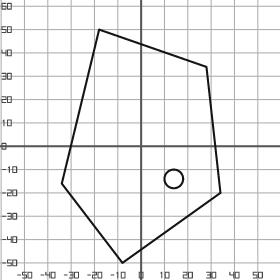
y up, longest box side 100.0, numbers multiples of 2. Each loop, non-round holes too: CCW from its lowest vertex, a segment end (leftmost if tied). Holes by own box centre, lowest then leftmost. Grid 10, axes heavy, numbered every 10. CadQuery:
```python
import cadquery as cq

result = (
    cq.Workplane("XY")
    .moveTo(-8.0, -50.0)
    .lineTo(34.0, -20.0)
    .lineTo(28.0, 34.0)
    .lineTo(-18.0, 50.0)
    .lineTo(-34.0, -16.0)
    .close()
    .moveTo(14.0, -14.0)
    .circle(4.0)
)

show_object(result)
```